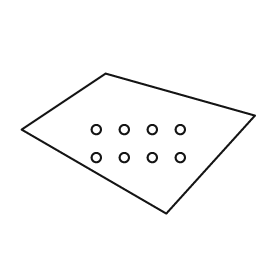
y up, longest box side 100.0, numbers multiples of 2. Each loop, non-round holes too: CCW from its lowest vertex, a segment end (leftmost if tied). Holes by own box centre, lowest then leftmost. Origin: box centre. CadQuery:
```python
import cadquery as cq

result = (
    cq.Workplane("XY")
    .moveTo(12.0, -30.0)
    .lineTo(50.0, 12.0)
    .lineTo(-14.0, 30.0)
    .lineTo(-50.0, 6.0)
    .close()
    .moveTo(-18.0, -6.0)
    .circle(2.0)
    .moveTo(-6.0, -6.0)
    .circle(2.0)
    .moveTo(6.0, -6.0)
    .circle(2.0)
    .moveTo(18.0, -6.0)
    .circle(2.0)
    .moveTo(-18.0, 6.0)
    .circle(2.0)
    .moveTo(-6.0, 6.0)
    .circle(2.0)
    .moveTo(6.0, 6.0)
    .circle(2.0)
    .moveTo(18.0, 6.0)
    .circle(2.0)
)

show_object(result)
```